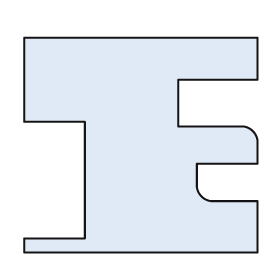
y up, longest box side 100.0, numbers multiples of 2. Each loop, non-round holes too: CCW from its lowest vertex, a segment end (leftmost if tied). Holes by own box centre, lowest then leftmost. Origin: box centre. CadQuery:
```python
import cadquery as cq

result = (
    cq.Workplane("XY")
    .moveTo(-50.0, -46.0)
    .lineTo(50.0, -46.0)
    .lineTo(50.0, -24.0)
    .lineTo(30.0, -24.0)
    .threePointArc((26.0, -22.0), (24.0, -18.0))
    .lineTo(24.0, -8.0)
    .lineTo(50.0, -8.0)
    .lineTo(50.0, 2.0)
    .threePointArc((48.0, 6.0), (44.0, 8.0))
    .lineTo(16.0, 8.0)
    .lineTo(16.0, 28.0)
    .lineTo(50.0, 28.0)
    .lineTo(50.0, 46.0)
    .lineTo(-50.0, 46.0)
    .lineTo(-50.0, 10.0)
    .lineTo(-24.0, 10.0)
    .lineTo(-24.0, -40.0)
    .lineTo(-50.0, -40.0)
    .close()
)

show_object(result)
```